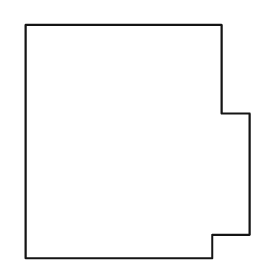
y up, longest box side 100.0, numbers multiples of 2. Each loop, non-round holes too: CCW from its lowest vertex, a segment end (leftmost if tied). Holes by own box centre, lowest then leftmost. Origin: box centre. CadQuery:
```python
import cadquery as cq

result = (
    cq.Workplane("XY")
    .moveTo(-48.0, -50.0)
    .lineTo(32.0, -50.0)
    .lineTo(32.0, -40.0)
    .lineTo(48.0, -40.0)
    .lineTo(48.0, 12.0)
    .lineTo(36.0, 12.0)
    .lineTo(36.0, 50.0)
    .lineTo(-48.0, 50.0)
    .close()
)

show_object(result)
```